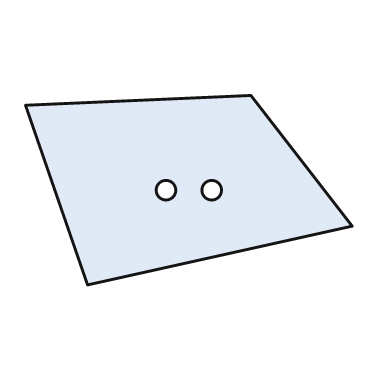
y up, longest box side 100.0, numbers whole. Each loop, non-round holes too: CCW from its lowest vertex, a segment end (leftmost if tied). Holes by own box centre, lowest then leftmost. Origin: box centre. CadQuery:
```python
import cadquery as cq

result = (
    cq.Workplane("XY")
    .moveTo(-31.0, -29.0)
    .lineTo(50.0, -11.0)
    .lineTo(19.0, 29.0)
    .lineTo(-50.0, 26.0)
    .close()
    .moveTo(-7.0, 0.0)
    .circle(3.0)
    .moveTo(7.0, 0.0)
    .circle(3.0)
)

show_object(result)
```